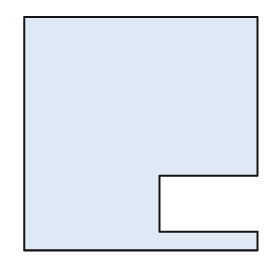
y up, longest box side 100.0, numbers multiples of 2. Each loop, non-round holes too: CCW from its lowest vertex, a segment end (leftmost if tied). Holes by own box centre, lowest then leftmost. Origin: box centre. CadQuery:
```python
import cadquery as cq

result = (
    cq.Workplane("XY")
    .moveTo(-50.0, -50.0)
    .lineTo(50.0, -50.0)
    .lineTo(50.0, -42.0)
    .lineTo(8.0, -42.0)
    .lineTo(8.0, -18.0)
    .lineTo(50.0, -18.0)
    .lineTo(50.0, 50.0)
    .lineTo(-50.0, 50.0)
    .close()
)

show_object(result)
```